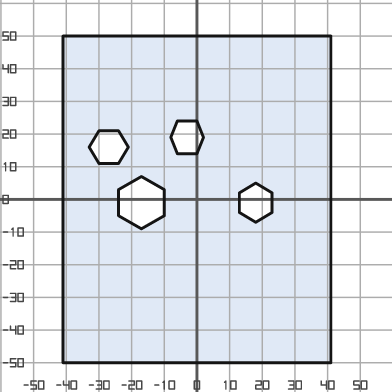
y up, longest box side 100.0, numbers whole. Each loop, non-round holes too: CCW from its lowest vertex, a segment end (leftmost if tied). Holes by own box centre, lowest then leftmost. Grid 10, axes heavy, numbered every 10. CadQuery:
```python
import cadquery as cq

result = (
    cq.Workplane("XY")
    .moveTo(-41.0, -50.0)
    .lineTo(41.0, -50.0)
    .lineTo(41.0, 50.0)
    .lineTo(-41.0, 50.0)
    .close()
    .moveTo(-17.0, -9.0)
    .lineTo(-10.0, -5.0)
    .lineTo(-10.0, 3.0)
    .lineTo(-17.0, 7.0)
    .lineTo(-24.0, 3.0)
    .lineTo(-24.0, -5.0)
    .close()
    .moveTo(18.0, -7.0)
    .lineTo(23.0, -4.0)
    .lineTo(23.0, 2.0)
    .lineTo(18.0, 5.0)
    .lineTo(13.0, 2.0)
    .lineTo(13.0, -4.0)
    .close()
    .moveTo(-30.0, 11.0)
    .lineTo(-24.0, 11.0)
    .lineTo(-21.0, 16.0)
    .lineTo(-24.0, 21.0)
    .lineTo(-30.0, 21.0)
    .lineTo(-33.0, 16.0)
    .close()
    .moveTo(-6.0, 14.0)
    .lineTo(0.0, 14.0)
    .lineTo(2.0, 19.0)
    .lineTo(0.0, 24.0)
    .lineTo(-6.0, 24.0)
    .lineTo(-8.0, 19.0)
    .close()
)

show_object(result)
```